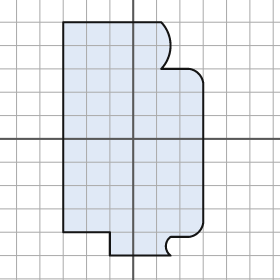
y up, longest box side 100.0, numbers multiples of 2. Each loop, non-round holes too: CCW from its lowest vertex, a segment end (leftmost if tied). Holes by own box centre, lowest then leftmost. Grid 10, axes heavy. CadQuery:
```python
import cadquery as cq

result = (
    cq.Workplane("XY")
    .moveTo(-10.0, -50.0)
    .lineTo(16.0, -50.0)
    .threePointArc((14.0, -46.0), (16.0, -42.0))
    .lineTo(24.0, -42.0)
    .threePointArc((28.0, -40.0), (30.0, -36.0))
    .lineTo(30.0, 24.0)
    .threePointArc((28.0, 28.0), (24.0, 30.0))
    .lineTo(12.0, 30.0)
    .threePointArc((16.0, 40.0), (12.0, 50.0))
    .lineTo(-30.0, 50.0)
    .lineTo(-30.0, -40.0)
    .lineTo(-10.0, -40.0)
    .close()
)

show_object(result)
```